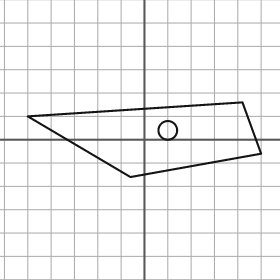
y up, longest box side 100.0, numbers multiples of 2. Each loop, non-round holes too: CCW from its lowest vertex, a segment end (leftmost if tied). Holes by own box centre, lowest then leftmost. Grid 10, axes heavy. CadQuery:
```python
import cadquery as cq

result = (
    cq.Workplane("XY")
    .moveTo(-6.0, -16.0)
    .lineTo(50.0, -6.0)
    .lineTo(42.0, 16.0)
    .lineTo(-50.0, 10.0)
    .close()
    .moveTo(10.0, 4.0)
    .circle(4.0)
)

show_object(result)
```